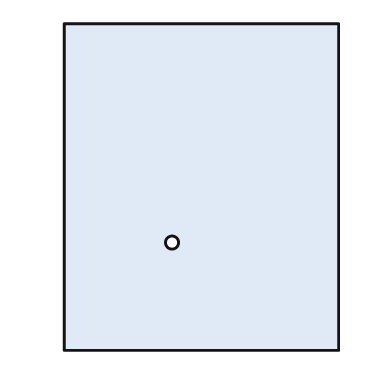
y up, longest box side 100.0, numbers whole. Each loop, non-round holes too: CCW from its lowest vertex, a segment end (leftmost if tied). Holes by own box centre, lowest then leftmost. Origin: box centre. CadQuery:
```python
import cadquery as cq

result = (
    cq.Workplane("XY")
    .moveTo(-42.0, -50.0)
    .lineTo(42.0, -50.0)
    .lineTo(42.0, 50.0)
    .lineTo(-42.0, 50.0)
    .close()
    .moveTo(-9.0, -17.0)
    .circle(2.0)
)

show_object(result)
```